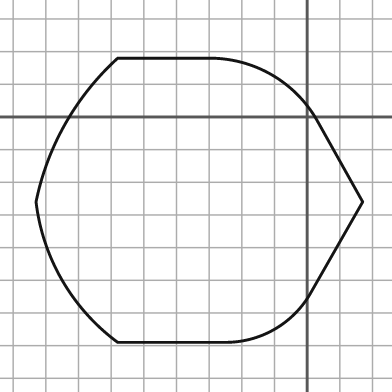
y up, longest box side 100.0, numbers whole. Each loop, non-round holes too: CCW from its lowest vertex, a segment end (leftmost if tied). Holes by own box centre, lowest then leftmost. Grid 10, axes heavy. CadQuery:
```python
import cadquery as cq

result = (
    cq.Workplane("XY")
    .moveTo(-58.0, -69.0)
    .lineTo(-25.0, -69.0)
    .threePointArc((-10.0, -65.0), (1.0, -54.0))
    .lineTo(17.0, -26.0)
    .lineTo(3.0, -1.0)
    .threePointArc((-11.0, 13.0), (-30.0, 18.0))
    .lineTo(-58.0, 18.0)
    .threePointArc((-74.0, -2.0), (-83.0, -26.0))
    .threePointArc((-75.0, -50.0), (-58.0, -69.0))
    .close()
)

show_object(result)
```